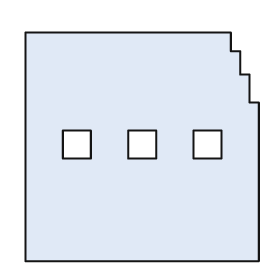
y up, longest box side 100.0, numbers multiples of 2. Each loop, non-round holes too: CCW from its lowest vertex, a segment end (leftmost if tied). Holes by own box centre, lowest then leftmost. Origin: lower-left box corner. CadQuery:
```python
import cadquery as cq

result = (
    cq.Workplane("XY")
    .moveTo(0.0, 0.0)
    .lineTo(100.0, 0.0)
    .lineTo(100.0, 68.0)
    .lineTo(96.0, 68.0)
    .lineTo(96.0, 80.0)
    .lineTo(92.0, 80.0)
    .lineTo(92.0, 90.0)
    .lineTo(88.0, 90.0)
    .lineTo(88.0, 98.0)
    .lineTo(0.0, 98.0)
    .close()
    .moveTo(16.0, 44.0)
    .lineTo(28.0, 44.0)
    .lineTo(28.0, 56.0)
    .lineTo(16.0, 56.0)
    .close()
    .moveTo(44.0, 44.0)
    .lineTo(56.0, 44.0)
    .lineTo(56.0, 56.0)
    .lineTo(44.0, 56.0)
    .close()
    .moveTo(72.0, 44.0)
    .lineTo(84.0, 44.0)
    .lineTo(84.0, 56.0)
    .lineTo(72.0, 56.0)
    .close()
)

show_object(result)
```